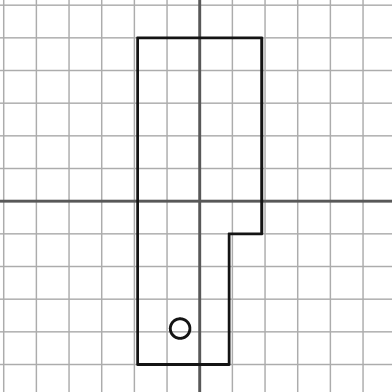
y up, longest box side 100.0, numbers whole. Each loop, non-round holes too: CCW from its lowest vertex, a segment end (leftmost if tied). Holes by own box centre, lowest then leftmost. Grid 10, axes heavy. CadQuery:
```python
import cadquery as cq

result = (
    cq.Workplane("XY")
    .moveTo(-19.0, -50.0)
    .lineTo(9.0, -50.0)
    .lineTo(9.0, -10.0)
    .lineTo(19.0, -10.0)
    .lineTo(19.0, 50.0)
    .lineTo(-19.0, 50.0)
    .close()
    .moveTo(-6.0, -39.0)
    .circle(3.0)
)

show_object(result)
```